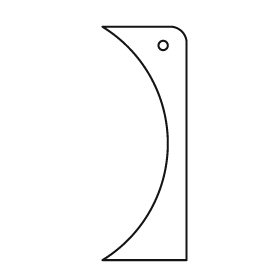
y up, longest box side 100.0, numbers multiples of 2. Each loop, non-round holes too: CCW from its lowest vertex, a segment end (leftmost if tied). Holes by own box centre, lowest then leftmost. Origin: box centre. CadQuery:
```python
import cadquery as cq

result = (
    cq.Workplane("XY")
    .moveTo(-18.0, -50.0)
    .lineTo(18.0, -50.0)
    .lineTo(18.0, 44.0)
    .threePointArc((16.0, 48.0), (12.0, 50.0))
    .lineTo(-18.0, 50.0)
    .threePointArc((10.0, 0.0), (-18.0, -50.0))
    .close()
    .moveTo(8.0, 42.0)
    .circle(2.0)
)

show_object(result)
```